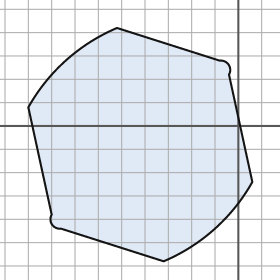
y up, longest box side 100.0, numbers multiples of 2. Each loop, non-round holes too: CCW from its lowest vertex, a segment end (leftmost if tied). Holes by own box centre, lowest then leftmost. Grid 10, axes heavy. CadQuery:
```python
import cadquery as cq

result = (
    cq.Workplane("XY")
    .moveTo(-32.0, -58.0)
    .threePointArc((-10.0, -44.0), (6.0, -24.0))
    .lineTo(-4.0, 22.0)
    .threePointArc((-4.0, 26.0), (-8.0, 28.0))
    .lineTo(-52.0, 42.0)
    .threePointArc((-74.0, 28.0), (-90.0, 8.0))
    .lineTo(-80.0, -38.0)
    .threePointArc((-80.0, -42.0), (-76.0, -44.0))
    .close()
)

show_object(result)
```